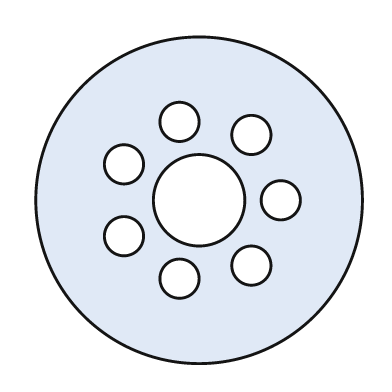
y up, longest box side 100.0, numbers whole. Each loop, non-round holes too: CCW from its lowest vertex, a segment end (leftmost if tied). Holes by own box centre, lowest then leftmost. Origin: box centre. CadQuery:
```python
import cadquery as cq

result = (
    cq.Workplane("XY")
    .moveTo(0.0, 0.0)
    .circle(50.0)
    .moveTo(-6.0, -24.0)
    .circle(6.0)
    .moveTo(16.0, -20.0)
    .circle(6.0)
    .moveTo(-23.0, -11.0)
    .circle(6.0)
    .moveTo(0.0, 0.0)
    .circle(14.0)
    .moveTo(25.0, 0.0)
    .circle(6.0)
    .moveTo(-23.0, 11.0)
    .circle(6.0)
    .moveTo(16.0, 20.0)
    .circle(6.0)
    .moveTo(-6.0, 24.0)
    .circle(6.0)
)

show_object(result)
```